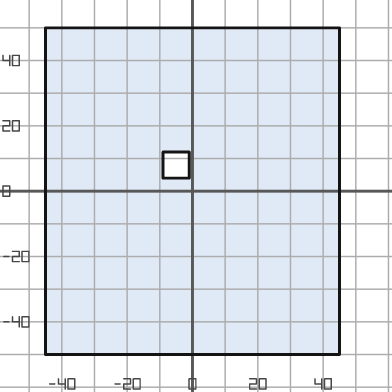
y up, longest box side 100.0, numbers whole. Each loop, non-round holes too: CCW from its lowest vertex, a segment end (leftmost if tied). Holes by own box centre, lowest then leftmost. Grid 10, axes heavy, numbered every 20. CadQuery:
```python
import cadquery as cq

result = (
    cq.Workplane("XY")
    .moveTo(-45.0, -50.0)
    .lineTo(45.0, -50.0)
    .lineTo(45.0, 50.0)
    .lineTo(-45.0, 50.0)
    .close()
    .moveTo(-9.0, 4.0)
    .lineTo(-1.0, 4.0)
    .lineTo(-1.0, 12.0)
    .lineTo(-9.0, 12.0)
    .close()
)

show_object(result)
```